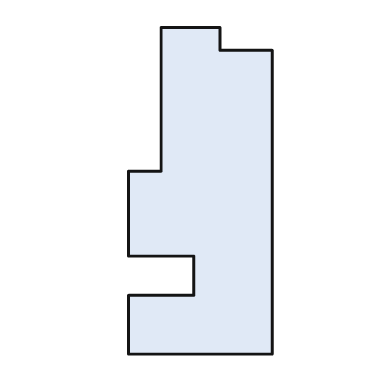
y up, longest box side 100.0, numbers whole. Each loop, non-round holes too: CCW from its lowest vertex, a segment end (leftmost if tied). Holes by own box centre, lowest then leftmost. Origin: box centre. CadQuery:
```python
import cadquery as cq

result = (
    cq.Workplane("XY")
    .moveTo(-22.0, -50.0)
    .lineTo(22.0, -50.0)
    .lineTo(22.0, 43.0)
    .lineTo(6.0, 43.0)
    .lineTo(6.0, 50.0)
    .lineTo(-12.0, 50.0)
    .lineTo(-12.0, 6.0)
    .lineTo(-22.0, 6.0)
    .lineTo(-22.0, -20.0)
    .lineTo(-2.0, -20.0)
    .lineTo(-2.0, -32.0)
    .lineTo(-22.0, -32.0)
    .close()
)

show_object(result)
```